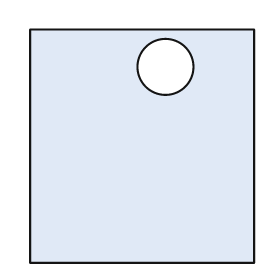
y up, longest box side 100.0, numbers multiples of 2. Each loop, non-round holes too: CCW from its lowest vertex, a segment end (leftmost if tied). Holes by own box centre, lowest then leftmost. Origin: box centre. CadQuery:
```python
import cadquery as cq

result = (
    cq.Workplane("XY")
    .moveTo(-48.0, -50.0)
    .lineTo(48.0, -50.0)
    .lineTo(48.0, 50.0)
    .lineTo(-48.0, 50.0)
    .close()
    .moveTo(10.0, 34.0)
    .circle(12.0)
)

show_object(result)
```